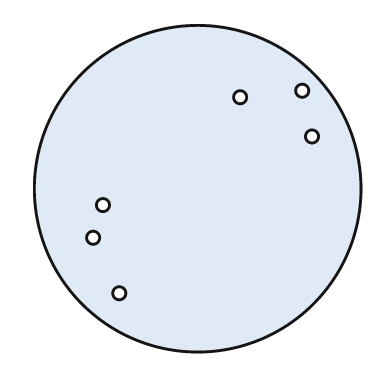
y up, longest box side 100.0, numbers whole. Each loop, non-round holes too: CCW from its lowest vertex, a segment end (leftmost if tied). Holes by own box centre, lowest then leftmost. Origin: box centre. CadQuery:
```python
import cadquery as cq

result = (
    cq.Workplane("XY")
    .moveTo(0.0, 0.0)
    .circle(50.0)
    .moveTo(-24.0, -32.0)
    .circle(2.0)
    .moveTo(-32.0, -15.0)
    .circle(2.0)
    .moveTo(-29.0, -5.0)
    .circle(2.0)
    .moveTo(35.0, 16.0)
    .circle(2.0)
    .moveTo(13.0, 28.0)
    .circle(2.0)
    .moveTo(32.0, 30.0)
    .circle(2.0)
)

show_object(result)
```